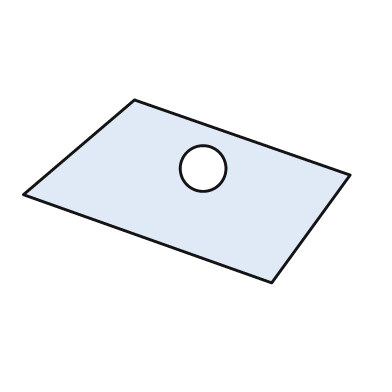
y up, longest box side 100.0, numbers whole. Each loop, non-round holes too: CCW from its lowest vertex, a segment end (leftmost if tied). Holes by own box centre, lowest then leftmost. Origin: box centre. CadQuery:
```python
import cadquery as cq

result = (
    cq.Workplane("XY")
    .moveTo(26.0, -28.0)
    .lineTo(50.0, 5.0)
    .lineTo(-16.0, 28.0)
    .lineTo(-50.0, -1.0)
    .close()
    .moveTo(5.0, 7.0)
    .circle(7.0)
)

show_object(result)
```